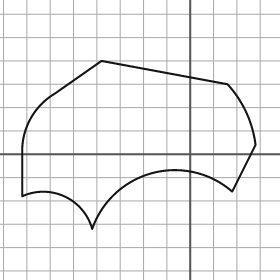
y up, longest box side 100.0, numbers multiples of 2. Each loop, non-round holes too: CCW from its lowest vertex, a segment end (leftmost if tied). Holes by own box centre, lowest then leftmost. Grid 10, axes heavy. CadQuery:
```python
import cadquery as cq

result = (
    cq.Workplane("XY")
    .moveTo(-42.0, -32.0)
    .threePointArc((-16.0, -8.0), (18.0, -16.0))
    .lineTo(28.0, 4.0)
    .threePointArc((24.0, 18.0), (16.0, 30.0))
    .lineTo(-38.0, 40.0)
    .lineTo(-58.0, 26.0)
    .threePointArc((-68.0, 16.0), (-72.0, 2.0))
    .lineTo(-72.0, -18.0)
    .threePointArc((-54.0, -18.0), (-42.0, -32.0))
    .close()
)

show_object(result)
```